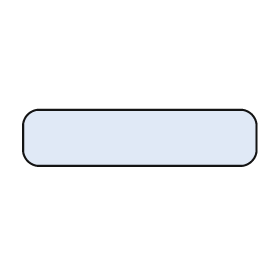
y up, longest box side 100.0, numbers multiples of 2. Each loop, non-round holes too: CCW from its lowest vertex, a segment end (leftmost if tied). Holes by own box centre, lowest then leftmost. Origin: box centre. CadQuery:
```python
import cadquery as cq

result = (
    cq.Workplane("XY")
    .moveTo(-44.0, -12.0)
    .lineTo(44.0, -12.0)
    .threePointArc((48.0, -10.0), (50.0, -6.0))
    .lineTo(50.0, 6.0)
    .threePointArc((48.0, 10.0), (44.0, 12.0))
    .lineTo(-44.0, 12.0)
    .threePointArc((-48.0, 10.0), (-50.0, 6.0))
    .lineTo(-50.0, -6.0)
    .threePointArc((-48.0, -10.0), (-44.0, -12.0))
    .close()
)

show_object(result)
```